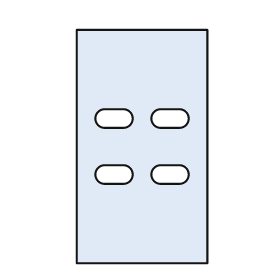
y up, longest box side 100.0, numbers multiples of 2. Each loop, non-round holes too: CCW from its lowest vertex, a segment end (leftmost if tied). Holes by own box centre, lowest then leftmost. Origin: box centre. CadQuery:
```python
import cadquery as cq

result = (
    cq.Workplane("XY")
    .moveTo(-28.0, -50.0)
    .lineTo(28.0, -50.0)
    .lineTo(28.0, 50.0)
    .lineTo(-28.0, 50.0)
    .close()
    .moveTo(-16.0, -16.0)
    .lineTo(-8.0, -16.0)
    .threePointArc((-4.0, -12.0), (-8.0, -8.0))
    .lineTo(-16.0, -8.0)
    .threePointArc((-20.0, -12.0), (-16.0, -16.0))
    .close()
    .moveTo(8.0, -16.0)
    .lineTo(16.0, -16.0)
    .threePointArc((20.0, -12.0), (16.0, -8.0))
    .lineTo(8.0, -8.0)
    .threePointArc((4.0, -12.0), (8.0, -16.0))
    .close()
    .moveTo(-16.0, 8.0)
    .lineTo(-8.0, 8.0)
    .threePointArc((-4.0, 12.0), (-8.0, 16.0))
    .lineTo(-16.0, 16.0)
    .threePointArc((-20.0, 12.0), (-16.0, 8.0))
    .close()
    .moveTo(8.0, 8.0)
    .lineTo(16.0, 8.0)
    .threePointArc((20.0, 12.0), (16.0, 16.0))
    .lineTo(8.0, 16.0)
    .threePointArc((4.0, 12.0), (8.0, 8.0))
    .close()
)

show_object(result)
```